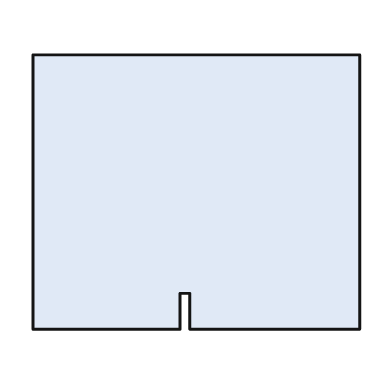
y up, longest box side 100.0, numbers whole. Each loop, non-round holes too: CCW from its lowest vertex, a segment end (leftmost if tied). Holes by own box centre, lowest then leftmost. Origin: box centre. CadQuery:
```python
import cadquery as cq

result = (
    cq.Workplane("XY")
    .moveTo(-50.0, -42.0)
    .lineTo(-5.0, -42.0)
    .lineTo(-5.0, -31.0)
    .lineTo(-2.0, -31.0)
    .lineTo(-2.0, -42.0)
    .lineTo(50.0, -42.0)
    .lineTo(50.0, 42.0)
    .lineTo(-50.0, 42.0)
    .close()
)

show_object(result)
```